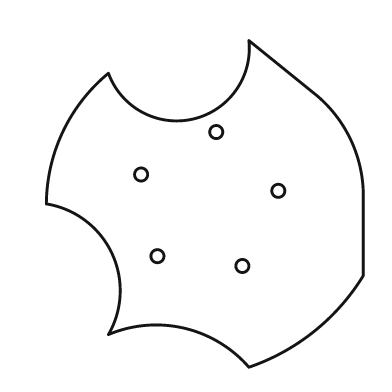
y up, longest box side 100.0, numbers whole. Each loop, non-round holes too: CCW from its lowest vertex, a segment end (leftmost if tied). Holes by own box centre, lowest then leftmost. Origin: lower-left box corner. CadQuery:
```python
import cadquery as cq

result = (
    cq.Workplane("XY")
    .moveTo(62.0, 0.0)
    .threePointArc((82.0, 11.0), (97.0, 28.0))
    .lineTo(97.0, 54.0)
    .threePointArc((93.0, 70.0), (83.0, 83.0))
    .lineTo(62.0, 100.0)
    .threePointArc((45.0, 76.0), (19.0, 90.0))
    .threePointArc((5.0, 72.0), (0.0, 50.0))
    .threePointArc((20.0, 35.0), (19.0, 10.0))
    .threePointArc((42.0, 12.0), (62.0, 0.0))
    .close()
    .moveTo(60.0, 31.0)
    .circle(2.0)
    .moveTo(34.0, 34.0)
    .circle(2.0)
    .moveTo(71.0, 54.0)
    .circle(2.0)
    .moveTo(29.0, 59.0)
    .circle(2.0)
    .moveTo(52.0, 72.0)
    .circle(2.0)
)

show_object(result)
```